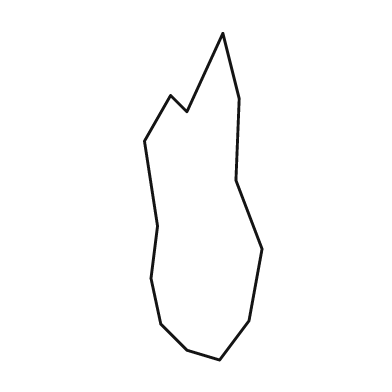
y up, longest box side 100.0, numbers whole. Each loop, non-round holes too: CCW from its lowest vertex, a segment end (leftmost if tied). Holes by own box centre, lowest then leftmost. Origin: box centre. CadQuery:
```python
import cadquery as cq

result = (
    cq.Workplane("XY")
    .moveTo(5.0, -50.0)
    .lineTo(14.0, -38.0)
    .lineTo(18.0, -16.0)
    .lineTo(10.0, 5.0)
    .lineTo(11.0, 30.0)
    .lineTo(6.0, 50.0)
    .lineTo(-5.0, 26.0)
    .lineTo(-10.0, 31.0)
    .lineTo(-18.0, 17.0)
    .lineTo(-14.0, -9.0)
    .lineTo(-16.0, -25.0)
    .lineTo(-13.0, -39.0)
    .lineTo(-5.0, -47.0)
    .close()
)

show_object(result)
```